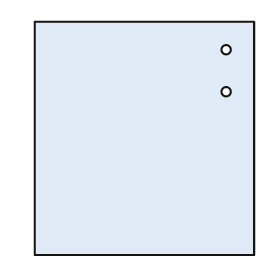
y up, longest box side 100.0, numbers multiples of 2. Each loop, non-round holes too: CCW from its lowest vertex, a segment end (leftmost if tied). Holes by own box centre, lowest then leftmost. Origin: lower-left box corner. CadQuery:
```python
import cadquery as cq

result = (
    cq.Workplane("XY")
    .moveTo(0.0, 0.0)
    .lineTo(94.0, 0.0)
    .lineTo(94.0, 100.0)
    .lineTo(0.0, 100.0)
    .close()
    .moveTo(82.0, 70.0)
    .circle(2.0)
    .moveTo(82.0, 88.0)
    .circle(2.0)
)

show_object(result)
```